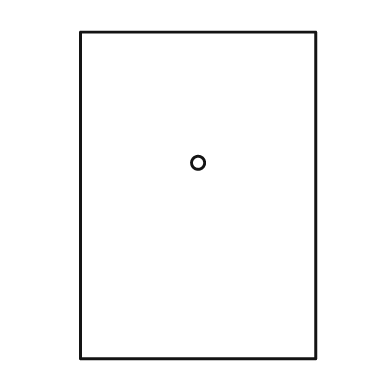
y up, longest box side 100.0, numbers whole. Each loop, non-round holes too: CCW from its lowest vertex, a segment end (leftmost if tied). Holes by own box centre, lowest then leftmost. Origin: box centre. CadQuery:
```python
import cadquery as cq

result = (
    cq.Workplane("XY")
    .moveTo(-36.0, -50.0)
    .lineTo(36.0, -50.0)
    .lineTo(36.0, 50.0)
    .lineTo(-36.0, 50.0)
    .close()
    .moveTo(0.0, 10.0)
    .circle(2.0)
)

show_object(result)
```